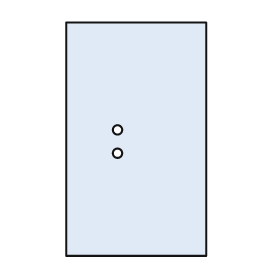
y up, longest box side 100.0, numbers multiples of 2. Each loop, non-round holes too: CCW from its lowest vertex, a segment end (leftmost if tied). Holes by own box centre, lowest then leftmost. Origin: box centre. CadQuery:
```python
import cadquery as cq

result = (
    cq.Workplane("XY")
    .moveTo(-30.0, -50.0)
    .lineTo(30.0, -50.0)
    .lineTo(30.0, 50.0)
    .lineTo(-30.0, 50.0)
    .close()
    .moveTo(-8.0, -6.0)
    .circle(2.0)
    .moveTo(-8.0, 4.0)
    .circle(2.0)
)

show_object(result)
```